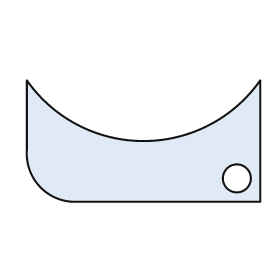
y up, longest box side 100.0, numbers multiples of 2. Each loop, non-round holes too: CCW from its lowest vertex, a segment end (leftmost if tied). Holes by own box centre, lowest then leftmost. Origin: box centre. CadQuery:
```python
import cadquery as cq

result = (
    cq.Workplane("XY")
    .moveTo(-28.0, -26.0)
    .lineTo(50.0, -26.0)
    .lineTo(50.0, 26.0)
    .threePointArc((0.0, 0.0), (-50.0, 26.0))
    .lineTo(-50.0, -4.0)
    .threePointArc((-44.0, -20.0), (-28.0, -26.0))
    .close()
    .moveTo(40.0, -16.0)
    .circle(6.0)
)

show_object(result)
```